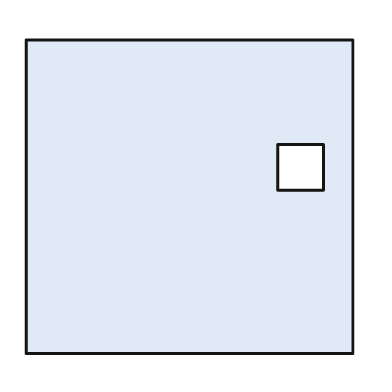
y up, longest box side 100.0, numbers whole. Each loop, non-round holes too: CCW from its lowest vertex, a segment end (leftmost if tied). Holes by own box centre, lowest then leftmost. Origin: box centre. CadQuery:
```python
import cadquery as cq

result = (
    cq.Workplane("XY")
    .moveTo(-50.0, -48.0)
    .lineTo(50.0, -48.0)
    .lineTo(50.0, 48.0)
    .lineTo(-50.0, 48.0)
    .close()
    .moveTo(27.0, 2.0)
    .lineTo(41.0, 2.0)
    .lineTo(41.0, 16.0)
    .lineTo(27.0, 16.0)
    .close()
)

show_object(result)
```